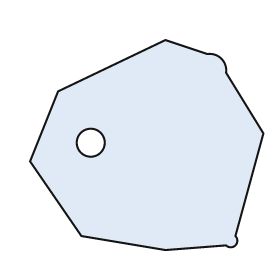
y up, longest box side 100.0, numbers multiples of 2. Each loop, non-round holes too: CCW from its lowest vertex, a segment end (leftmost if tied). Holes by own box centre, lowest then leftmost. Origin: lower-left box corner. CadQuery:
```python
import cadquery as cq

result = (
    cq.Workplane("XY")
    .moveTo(58.0, 0.0)
    .lineTo(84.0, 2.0)
    .threePointArc((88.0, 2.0), (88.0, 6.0))
    .lineTo(100.0, 50.0)
    .lineTo(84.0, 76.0)
    .threePointArc((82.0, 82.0), (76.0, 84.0))
    .lineTo(58.0, 90.0)
    .lineTo(12.0, 68.0)
    .lineTo(0.0, 38.0)
    .lineTo(22.0, 6.0)
    .close()
    .moveTo(26.0, 46.0)
    .circle(6.0)
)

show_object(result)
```